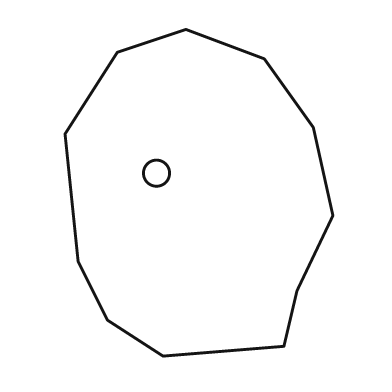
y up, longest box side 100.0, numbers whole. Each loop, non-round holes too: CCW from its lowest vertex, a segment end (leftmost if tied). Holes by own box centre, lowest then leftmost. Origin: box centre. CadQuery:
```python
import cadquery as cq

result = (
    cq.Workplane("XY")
    .moveTo(-11.0, -50.0)
    .lineTo(26.0, -47.0)
    .lineTo(30.0, -30.0)
    .lineTo(41.0, -7.0)
    .lineTo(35.0, 20.0)
    .lineTo(20.0, 41.0)
    .lineTo(-4.0, 50.0)
    .lineTo(-25.0, 43.0)
    .lineTo(-41.0, 18.0)
    .lineTo(-37.0, -21.0)
    .lineTo(-28.0, -39.0)
    .close()
    .moveTo(-13.0, 6.0)
    .circle(4.0)
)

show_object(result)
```